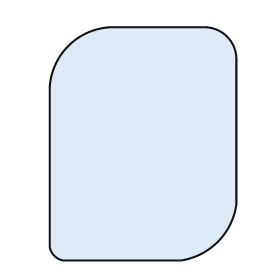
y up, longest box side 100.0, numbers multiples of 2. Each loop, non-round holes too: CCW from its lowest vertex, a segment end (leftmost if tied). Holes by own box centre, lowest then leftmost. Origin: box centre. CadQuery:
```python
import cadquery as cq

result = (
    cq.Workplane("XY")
    .moveTo(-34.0, -50.0)
    .lineTo(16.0, -50.0)
    .threePointArc((32.0, -42.0), (40.0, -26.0))
    .lineTo(40.0, 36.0)
    .threePointArc((36.0, 46.0), (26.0, 50.0))
    .lineTo(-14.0, 50.0)
    .threePointArc((-32.0, 42.0), (-40.0, 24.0))
    .lineTo(-40.0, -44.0)
    .threePointArc((-38.0, -48.0), (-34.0, -50.0))
    .close()
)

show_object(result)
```